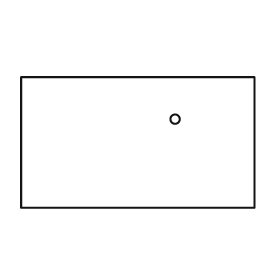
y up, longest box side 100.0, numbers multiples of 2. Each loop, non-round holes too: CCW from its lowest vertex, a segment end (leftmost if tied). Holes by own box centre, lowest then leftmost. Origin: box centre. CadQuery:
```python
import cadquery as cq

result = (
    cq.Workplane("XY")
    .moveTo(-50.0, -28.0)
    .lineTo(50.0, -28.0)
    .lineTo(50.0, 28.0)
    .lineTo(-50.0, 28.0)
    .close()
    .moveTo(16.0, 10.0)
    .circle(2.0)
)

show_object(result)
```